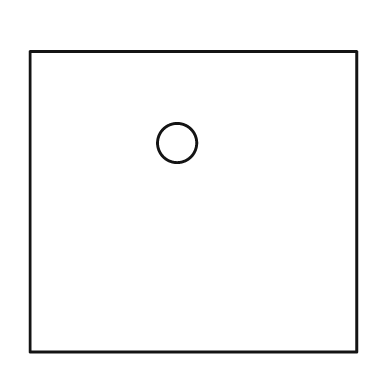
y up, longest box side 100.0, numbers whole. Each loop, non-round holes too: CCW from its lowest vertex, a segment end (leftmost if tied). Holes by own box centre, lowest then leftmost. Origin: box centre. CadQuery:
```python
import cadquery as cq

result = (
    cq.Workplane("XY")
    .moveTo(-50.0, -46.0)
    .lineTo(50.0, -46.0)
    .lineTo(50.0, 46.0)
    .lineTo(-50.0, 46.0)
    .close()
    .moveTo(-5.0, 18.0)
    .circle(6.0)
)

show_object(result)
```